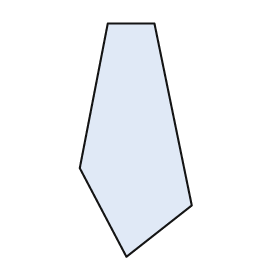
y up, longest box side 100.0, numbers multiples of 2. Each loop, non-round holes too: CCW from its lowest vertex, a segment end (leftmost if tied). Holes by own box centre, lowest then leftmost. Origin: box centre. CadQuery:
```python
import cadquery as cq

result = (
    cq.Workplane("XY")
    .moveTo(-4.0, -50.0)
    .lineTo(24.0, -28.0)
    .lineTo(8.0, 50.0)
    .lineTo(-12.0, 50.0)
    .lineTo(-24.0, -12.0)
    .close()
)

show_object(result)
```